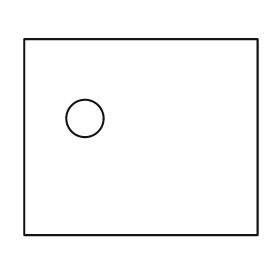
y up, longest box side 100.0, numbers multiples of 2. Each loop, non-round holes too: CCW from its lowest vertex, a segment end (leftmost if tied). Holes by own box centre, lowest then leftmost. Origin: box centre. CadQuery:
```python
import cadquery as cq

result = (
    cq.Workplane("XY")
    .moveTo(-50.0, -42.0)
    .lineTo(50.0, -42.0)
    .lineTo(50.0, 42.0)
    .lineTo(-50.0, 42.0)
    .close()
    .moveTo(-24.0, 8.0)
    .circle(8.0)
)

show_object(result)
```